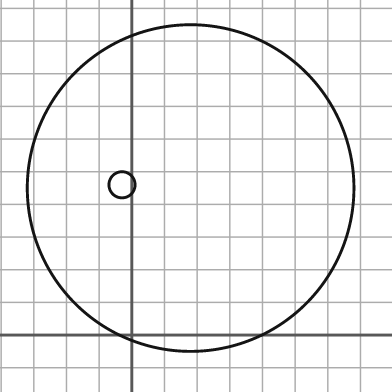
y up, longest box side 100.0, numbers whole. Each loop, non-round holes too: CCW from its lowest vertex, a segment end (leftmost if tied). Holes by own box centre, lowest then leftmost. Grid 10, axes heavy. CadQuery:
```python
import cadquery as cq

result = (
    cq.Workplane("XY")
    .moveTo(18.0, 45.0)
    .circle(50.0)
    .moveTo(-3.0, 46.0)
    .circle(4.0)
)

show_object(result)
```